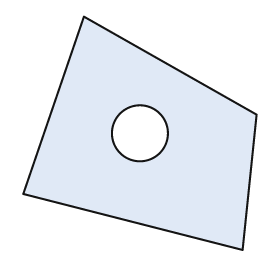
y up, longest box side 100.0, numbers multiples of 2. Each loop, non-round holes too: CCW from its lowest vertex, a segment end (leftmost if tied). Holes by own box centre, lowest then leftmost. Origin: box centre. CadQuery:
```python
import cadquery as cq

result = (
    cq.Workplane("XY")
    .moveTo(44.0, -50.0)
    .lineTo(50.0, 8.0)
    .lineTo(-24.0, 50.0)
    .lineTo(-50.0, -26.0)
    .close()
    .moveTo(0.0, 0.0)
    .circle(12.0)
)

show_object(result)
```